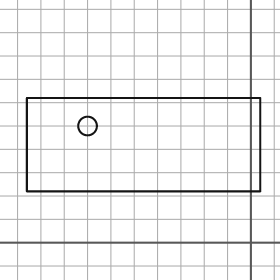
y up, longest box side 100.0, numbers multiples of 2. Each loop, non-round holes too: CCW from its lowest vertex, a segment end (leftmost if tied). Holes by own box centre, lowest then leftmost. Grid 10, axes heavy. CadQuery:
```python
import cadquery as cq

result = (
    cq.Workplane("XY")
    .moveTo(-96.0, 22.0)
    .lineTo(4.0, 22.0)
    .lineTo(4.0, 62.0)
    .lineTo(-96.0, 62.0)
    .close()
    .moveTo(-70.0, 50.0)
    .circle(4.0)
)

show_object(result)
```